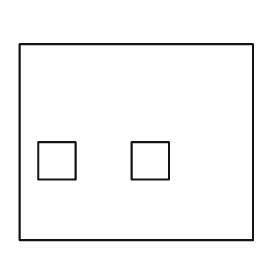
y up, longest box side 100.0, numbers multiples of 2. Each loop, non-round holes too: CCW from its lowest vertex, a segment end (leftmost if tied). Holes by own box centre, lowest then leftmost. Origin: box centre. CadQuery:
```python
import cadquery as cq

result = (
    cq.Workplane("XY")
    .moveTo(-50.0, -42.0)
    .lineTo(50.0, -42.0)
    .lineTo(50.0, 42.0)
    .lineTo(-50.0, 42.0)
    .close()
    .moveTo(-42.0, -16.0)
    .lineTo(-26.0, -16.0)
    .lineTo(-26.0, 0.0)
    .lineTo(-42.0, 0.0)
    .close()
    .moveTo(-2.0, -16.0)
    .lineTo(14.0, -16.0)
    .lineTo(14.0, 0.0)
    .lineTo(-2.0, 0.0)
    .close()
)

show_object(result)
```